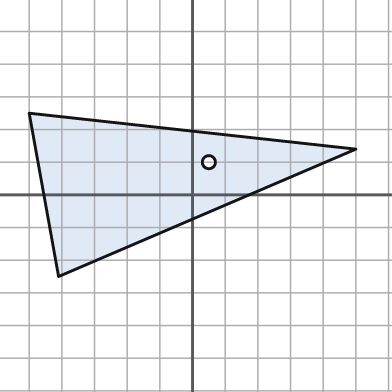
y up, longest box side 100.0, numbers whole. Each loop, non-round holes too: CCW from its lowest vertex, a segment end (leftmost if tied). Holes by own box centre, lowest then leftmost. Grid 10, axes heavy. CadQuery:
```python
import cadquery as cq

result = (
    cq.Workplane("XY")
    .moveTo(-41.0, -25.0)
    .lineTo(50.0, 14.0)
    .lineTo(-50.0, 25.0)
    .close()
    .moveTo(5.0, 10.0)
    .circle(2.0)
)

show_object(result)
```